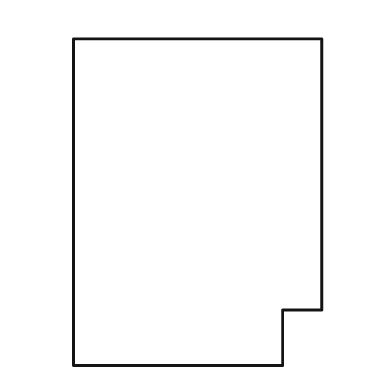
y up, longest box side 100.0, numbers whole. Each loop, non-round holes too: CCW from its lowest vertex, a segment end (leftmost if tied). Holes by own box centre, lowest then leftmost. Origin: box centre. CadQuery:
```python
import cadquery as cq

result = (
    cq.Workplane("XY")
    .moveTo(-38.0, -50.0)
    .lineTo(26.0, -50.0)
    .lineTo(26.0, -33.0)
    .lineTo(38.0, -33.0)
    .lineTo(38.0, 50.0)
    .lineTo(-38.0, 50.0)
    .close()
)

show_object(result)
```